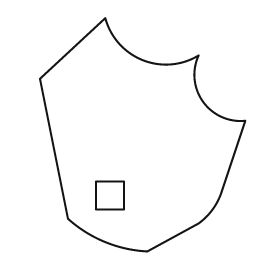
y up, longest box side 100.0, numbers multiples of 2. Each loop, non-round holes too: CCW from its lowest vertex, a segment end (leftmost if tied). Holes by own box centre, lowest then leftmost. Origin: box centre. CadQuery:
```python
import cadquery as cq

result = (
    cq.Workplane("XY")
    .moveTo(2.0, -50.0)
    .lineTo(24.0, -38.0)
    .threePointArc((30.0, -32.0), (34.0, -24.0))
    .lineTo(44.0, 6.0)
    .threePointArc((26.0, 14.0), (24.0, 34.0))
    .threePointArc((0.0, 32.0), (-16.0, 50.0))
    .lineTo(-44.0, 24.0)
    .lineTo(-32.0, -36.0)
    .threePointArc((-16.0, -46.0), (2.0, -50.0))
    .close()
    .moveTo(-20.0, -32.0)
    .lineTo(-8.0, -32.0)
    .lineTo(-8.0, -20.0)
    .lineTo(-20.0, -20.0)
    .close()
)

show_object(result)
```